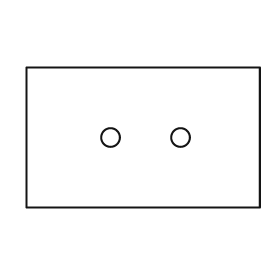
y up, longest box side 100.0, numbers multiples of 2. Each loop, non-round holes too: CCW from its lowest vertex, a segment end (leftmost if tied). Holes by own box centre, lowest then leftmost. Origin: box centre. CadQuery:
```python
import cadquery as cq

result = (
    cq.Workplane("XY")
    .moveTo(-50.0, -30.0)
    .lineTo(50.0, -30.0)
    .lineTo(50.0, 30.0)
    .lineTo(-50.0, 30.0)
    .close()
    .moveTo(-14.0, 0.0)
    .circle(4.0)
    .moveTo(16.0, 0.0)
    .circle(4.0)
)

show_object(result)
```